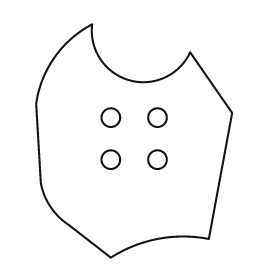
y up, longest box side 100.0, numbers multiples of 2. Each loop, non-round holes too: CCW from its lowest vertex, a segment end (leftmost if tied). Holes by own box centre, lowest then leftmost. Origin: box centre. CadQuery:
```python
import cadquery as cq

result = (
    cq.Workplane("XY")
    .moveTo(-10.0, -50.0)
    .threePointArc((10.0, -42.0), (32.0, -42.0))
    .lineTo(42.0, 12.0)
    .lineTo(24.0, 38.0)
    .threePointArc((-2.0, 26.0), (-18.0, 50.0))
    .threePointArc((-34.0, 36.0), (-42.0, 16.0))
    .lineTo(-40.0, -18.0)
    .threePointArc((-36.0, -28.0), (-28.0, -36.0))
    .close()
    .moveTo(-10.0, -8.0)
    .circle(4.0)
    .moveTo(10.0, -8.0)
    .circle(4.0)
    .moveTo(-10.0, 10.0)
    .circle(4.0)
    .moveTo(10.0, 10.0)
    .circle(4.0)
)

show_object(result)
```